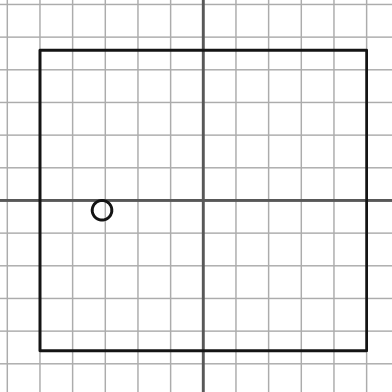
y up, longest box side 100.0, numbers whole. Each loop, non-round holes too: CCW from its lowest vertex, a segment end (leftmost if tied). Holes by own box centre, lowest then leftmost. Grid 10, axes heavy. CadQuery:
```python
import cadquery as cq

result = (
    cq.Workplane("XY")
    .moveTo(-50.0, -46.0)
    .lineTo(50.0, -46.0)
    .lineTo(50.0, 46.0)
    .lineTo(-50.0, 46.0)
    .close()
    .moveTo(-31.0, -3.0)
    .circle(3.0)
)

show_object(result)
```